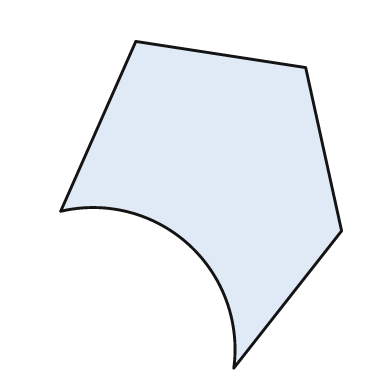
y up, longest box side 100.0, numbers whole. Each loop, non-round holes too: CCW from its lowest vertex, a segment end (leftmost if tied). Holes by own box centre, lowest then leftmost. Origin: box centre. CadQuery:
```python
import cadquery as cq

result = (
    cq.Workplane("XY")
    .moveTo(10.0, -50.0)
    .lineTo(43.0, -8.0)
    .lineTo(32.0, 42.0)
    .lineTo(-20.0, 50.0)
    .lineTo(-43.0, -2.0)
    .threePointArc((-4.0, -12.0), (10.0, -50.0))
    .close()
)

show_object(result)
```